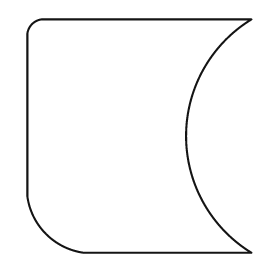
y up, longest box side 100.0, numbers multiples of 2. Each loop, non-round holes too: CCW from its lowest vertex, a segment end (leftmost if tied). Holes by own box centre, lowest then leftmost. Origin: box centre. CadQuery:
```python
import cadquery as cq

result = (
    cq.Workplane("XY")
    .moveTo(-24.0, -50.0)
    .lineTo(48.0, -50.0)
    .threePointArc((20.0, 0.0), (48.0, 50.0))
    .lineTo(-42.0, 50.0)
    .threePointArc((-46.0, 48.0), (-48.0, 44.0))
    .lineTo(-48.0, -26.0)
    .threePointArc((-40.0, -42.0), (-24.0, -50.0))
    .close()
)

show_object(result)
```